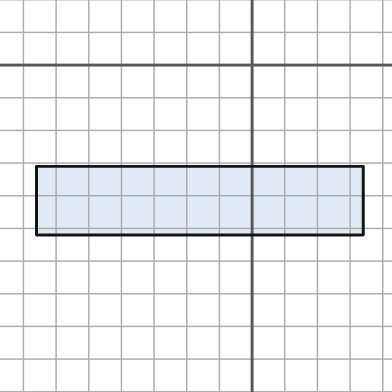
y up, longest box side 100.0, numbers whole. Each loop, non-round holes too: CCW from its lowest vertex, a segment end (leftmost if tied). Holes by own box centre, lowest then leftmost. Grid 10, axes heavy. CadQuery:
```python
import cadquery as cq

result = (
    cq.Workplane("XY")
    .moveTo(-66.0, -52.0)
    .lineTo(34.0, -52.0)
    .lineTo(34.0, -31.0)
    .lineTo(-66.0, -31.0)
    .close()
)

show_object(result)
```